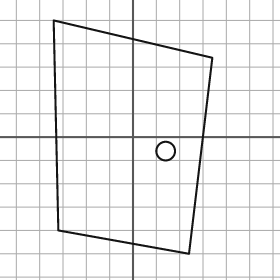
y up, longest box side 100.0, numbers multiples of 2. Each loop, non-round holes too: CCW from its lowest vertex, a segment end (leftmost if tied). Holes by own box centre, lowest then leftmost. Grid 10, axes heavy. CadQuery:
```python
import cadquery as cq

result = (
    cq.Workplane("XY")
    .moveTo(24.0, -50.0)
    .lineTo(34.0, 34.0)
    .lineTo(-34.0, 50.0)
    .lineTo(-32.0, -40.0)
    .close()
    .moveTo(14.0, -6.0)
    .circle(4.0)
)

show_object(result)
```